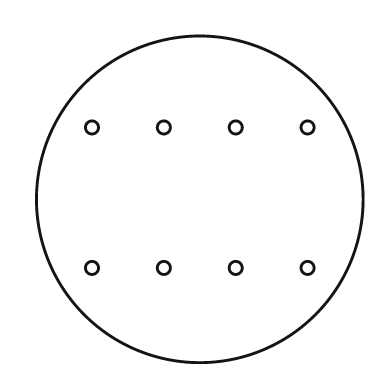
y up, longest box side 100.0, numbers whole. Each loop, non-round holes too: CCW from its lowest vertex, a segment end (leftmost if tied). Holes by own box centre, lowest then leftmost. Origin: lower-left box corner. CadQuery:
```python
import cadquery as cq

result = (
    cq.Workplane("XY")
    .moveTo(50.0, 50.0)
    .circle(50.0)
    .moveTo(17.0, 29.0)
    .circle(2.0)
    .moveTo(39.0, 29.0)
    .circle(2.0)
    .moveTo(61.0, 29.0)
    .circle(2.0)
    .moveTo(83.0, 29.0)
    .circle(2.0)
    .moveTo(17.0, 72.0)
    .circle(2.0)
    .moveTo(39.0, 72.0)
    .circle(2.0)
    .moveTo(61.0, 72.0)
    .circle(2.0)
    .moveTo(83.0, 72.0)
    .circle(2.0)
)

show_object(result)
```